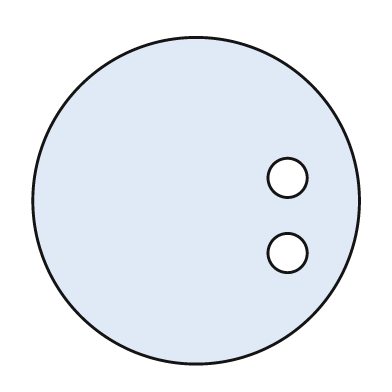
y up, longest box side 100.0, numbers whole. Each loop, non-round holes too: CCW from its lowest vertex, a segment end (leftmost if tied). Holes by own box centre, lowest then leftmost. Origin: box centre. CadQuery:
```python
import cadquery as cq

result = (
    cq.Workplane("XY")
    .moveTo(0.0, 0.0)
    .circle(50.0)
    .moveTo(28.0, -16.0)
    .circle(6.0)
    .moveTo(28.0, 7.0)
    .circle(6.0)
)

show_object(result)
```